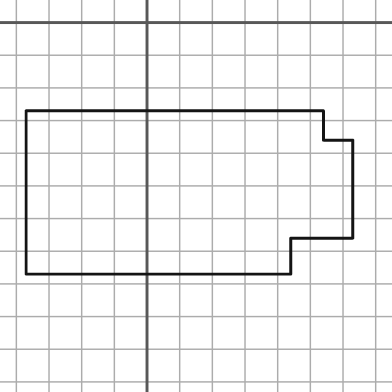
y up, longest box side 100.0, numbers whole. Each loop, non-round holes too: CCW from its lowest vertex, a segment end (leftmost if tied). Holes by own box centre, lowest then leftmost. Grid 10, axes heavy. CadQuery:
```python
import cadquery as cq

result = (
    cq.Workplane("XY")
    .moveTo(-37.0, -77.0)
    .lineTo(44.0, -77.0)
    .lineTo(44.0, -66.0)
    .lineTo(63.0, -66.0)
    .lineTo(63.0, -36.0)
    .lineTo(54.0, -36.0)
    .lineTo(54.0, -27.0)
    .lineTo(-37.0, -27.0)
    .close()
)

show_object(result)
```